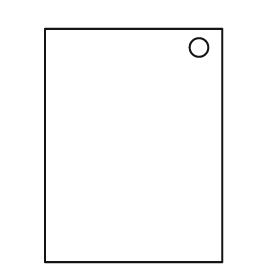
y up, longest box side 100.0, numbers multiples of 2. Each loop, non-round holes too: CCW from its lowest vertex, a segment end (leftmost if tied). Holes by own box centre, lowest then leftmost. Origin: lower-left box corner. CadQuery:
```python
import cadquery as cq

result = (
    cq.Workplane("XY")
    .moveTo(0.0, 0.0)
    .lineTo(76.0, 0.0)
    .lineTo(76.0, 100.0)
    .lineTo(0.0, 100.0)
    .close()
    .moveTo(66.0, 92.0)
    .circle(4.0)
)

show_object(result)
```